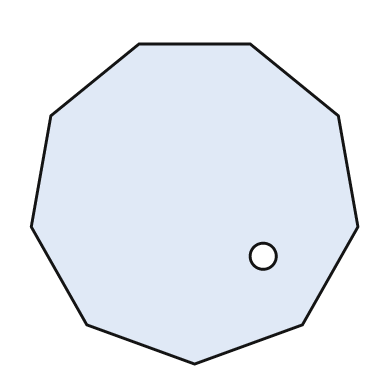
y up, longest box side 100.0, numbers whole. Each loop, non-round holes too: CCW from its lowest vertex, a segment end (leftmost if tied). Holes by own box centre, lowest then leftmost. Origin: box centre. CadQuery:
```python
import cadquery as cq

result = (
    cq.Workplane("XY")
    .moveTo(0.0, -49.0)
    .lineTo(33.0, -37.0)
    .lineTo(50.0, -7.0)
    .lineTo(44.0, 27.0)
    .lineTo(17.0, 49.0)
    .lineTo(-17.0, 49.0)
    .lineTo(-44.0, 27.0)
    .lineTo(-50.0, -7.0)
    .lineTo(-33.0, -37.0)
    .close()
    .moveTo(21.0, -16.0)
    .circle(4.0)
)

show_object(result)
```